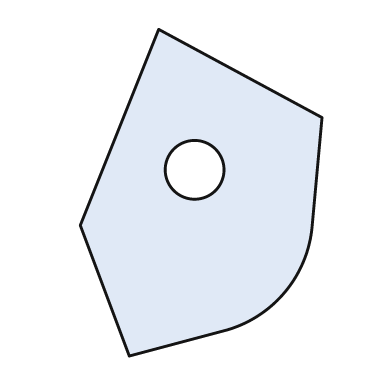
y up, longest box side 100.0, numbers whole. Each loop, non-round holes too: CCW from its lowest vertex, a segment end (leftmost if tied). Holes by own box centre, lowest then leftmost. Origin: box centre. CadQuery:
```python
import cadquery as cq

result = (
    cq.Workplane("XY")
    .moveTo(-22.0, -50.0)
    .lineTo(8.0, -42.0)
    .threePointArc((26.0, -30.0), (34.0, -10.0))
    .lineTo(37.0, 23.0)
    .lineTo(-13.0, 50.0)
    .lineTo(-37.0, -10.0)
    .close()
    .moveTo(-2.0, 7.0)
    .circle(9.0)
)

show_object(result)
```